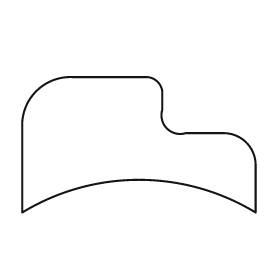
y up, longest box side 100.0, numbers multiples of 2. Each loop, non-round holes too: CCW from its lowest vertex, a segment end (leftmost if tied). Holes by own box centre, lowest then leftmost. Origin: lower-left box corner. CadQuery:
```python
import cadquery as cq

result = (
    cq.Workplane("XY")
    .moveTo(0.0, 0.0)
    .threePointArc((50.0, 14.0), (100.0, 0.0))
    .lineTo(100.0, 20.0)
    .threePointArc((96.0, 30.0), (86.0, 34.0))
    .lineTo(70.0, 34.0)
    .threePointArc((62.0, 36.0), (60.0, 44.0))
    .lineTo(60.0, 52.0)
    .threePointArc((58.0, 56.0), (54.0, 58.0))
    .lineTo(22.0, 58.0)
    .threePointArc((6.0, 52.0), (0.0, 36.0))
    .close()
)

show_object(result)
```